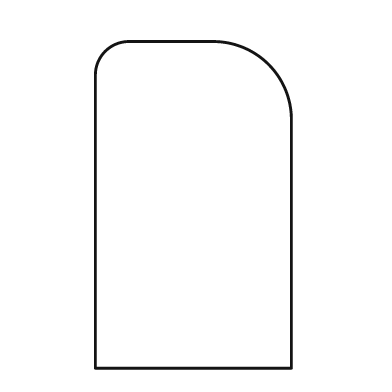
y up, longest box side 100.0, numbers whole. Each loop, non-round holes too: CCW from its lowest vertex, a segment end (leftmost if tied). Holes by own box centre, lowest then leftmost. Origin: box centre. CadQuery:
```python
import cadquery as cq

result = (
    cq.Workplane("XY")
    .moveTo(-30.0, -50.0)
    .lineTo(30.0, -50.0)
    .lineTo(30.0, 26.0)
    .threePointArc((23.0, 43.0), (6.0, 50.0))
    .lineTo(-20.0, 50.0)
    .threePointArc((-27.0, 47.0), (-30.0, 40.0))
    .close()
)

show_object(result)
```